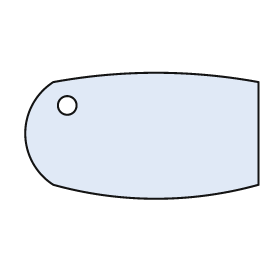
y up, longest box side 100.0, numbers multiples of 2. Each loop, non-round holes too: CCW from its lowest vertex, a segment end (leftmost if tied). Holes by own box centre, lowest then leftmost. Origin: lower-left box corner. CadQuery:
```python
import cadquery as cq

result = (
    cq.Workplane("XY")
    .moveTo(12.0, 6.0)
    .threePointArc((56.0, 0.0), (100.0, 6.0))
    .lineTo(100.0, 50.0)
    .threePointArc((56.0, 54.0), (12.0, 50.0))
    .threePointArc((0.0, 28.0), (12.0, 6.0))
    .close()
    .moveTo(18.0, 40.0)
    .circle(4.0)
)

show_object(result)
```